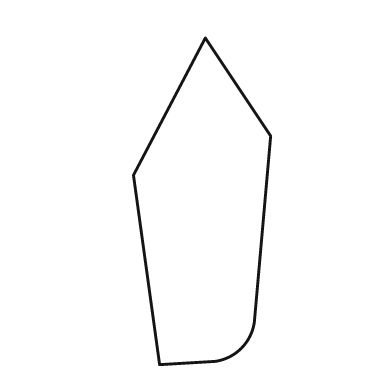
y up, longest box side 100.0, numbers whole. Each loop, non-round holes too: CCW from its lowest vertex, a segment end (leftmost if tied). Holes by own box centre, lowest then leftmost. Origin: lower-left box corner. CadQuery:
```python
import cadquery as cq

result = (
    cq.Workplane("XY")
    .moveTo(8.0, 0.0)
    .lineTo(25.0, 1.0)
    .threePointArc((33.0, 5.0), (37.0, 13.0))
    .lineTo(42.0, 70.0)
    .lineTo(22.0, 100.0)
    .lineTo(0.0, 58.0)
    .close()
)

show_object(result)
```